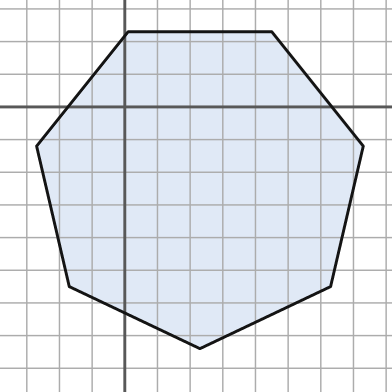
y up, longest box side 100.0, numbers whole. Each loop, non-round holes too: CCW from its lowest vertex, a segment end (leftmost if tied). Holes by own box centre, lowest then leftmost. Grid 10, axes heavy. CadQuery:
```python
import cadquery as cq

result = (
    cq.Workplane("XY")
    .moveTo(23.0, -74.0)
    .lineTo(63.0, -55.0)
    .lineTo(73.0, -12.0)
    .lineTo(45.0, 23.0)
    .lineTo(1.0, 23.0)
    .lineTo(-27.0, -12.0)
    .lineTo(-17.0, -55.0)
    .close()
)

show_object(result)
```